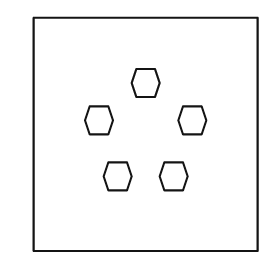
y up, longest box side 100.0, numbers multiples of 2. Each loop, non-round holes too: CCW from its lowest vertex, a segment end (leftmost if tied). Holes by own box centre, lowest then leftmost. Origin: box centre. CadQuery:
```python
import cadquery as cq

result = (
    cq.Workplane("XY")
    .moveTo(-48.0, -50.0)
    .lineTo(48.0, -50.0)
    .lineTo(48.0, 50.0)
    .lineTo(-48.0, 50.0)
    .close()
    .moveTo(-16.0, -24.0)
    .lineTo(-8.0, -24.0)
    .lineTo(-6.0, -18.0)
    .lineTo(-8.0, -12.0)
    .lineTo(-16.0, -12.0)
    .lineTo(-18.0, -18.0)
    .close()
    .moveTo(8.0, -24.0)
    .lineTo(16.0, -24.0)
    .lineTo(18.0, -18.0)
    .lineTo(16.0, -12.0)
    .lineTo(8.0, -12.0)
    .lineTo(6.0, -18.0)
    .close()
    .moveTo(-24.0, 0.0)
    .lineTo(-16.0, 0.0)
    .lineTo(-14.0, 6.0)
    .lineTo(-16.0, 12.0)
    .lineTo(-24.0, 12.0)
    .lineTo(-26.0, 6.0)
    .close()
    .moveTo(16.0, 0.0)
    .lineTo(24.0, 0.0)
    .lineTo(26.0, 6.0)
    .lineTo(24.0, 12.0)
    .lineTo(16.0, 12.0)
    .lineTo(14.0, 6.0)
    .close()
    .moveTo(-4.0, 16.0)
    .lineTo(4.0, 16.0)
    .lineTo(6.0, 22.0)
    .lineTo(4.0, 28.0)
    .lineTo(-4.0, 28.0)
    .lineTo(-6.0, 22.0)
    .close()
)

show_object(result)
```